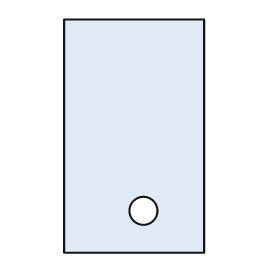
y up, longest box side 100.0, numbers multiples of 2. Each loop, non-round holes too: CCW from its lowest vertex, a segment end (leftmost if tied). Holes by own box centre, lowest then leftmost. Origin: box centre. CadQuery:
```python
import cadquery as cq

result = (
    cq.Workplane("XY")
    .moveTo(-30.0, -50.0)
    .lineTo(30.0, -50.0)
    .lineTo(30.0, 50.0)
    .lineTo(-30.0, 50.0)
    .close()
    .moveTo(4.0, -32.0)
    .circle(6.0)
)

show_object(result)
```